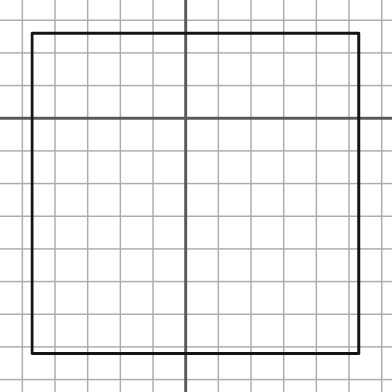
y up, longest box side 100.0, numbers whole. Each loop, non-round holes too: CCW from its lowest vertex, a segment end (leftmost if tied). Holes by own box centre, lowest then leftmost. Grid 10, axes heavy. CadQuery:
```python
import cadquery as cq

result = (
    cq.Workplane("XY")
    .moveTo(-47.0, -72.0)
    .lineTo(53.0, -72.0)
    .lineTo(53.0, 26.0)
    .lineTo(-47.0, 26.0)
    .close()
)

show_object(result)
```